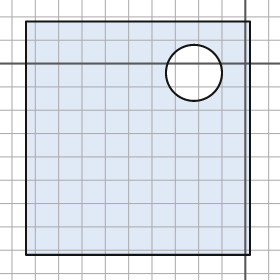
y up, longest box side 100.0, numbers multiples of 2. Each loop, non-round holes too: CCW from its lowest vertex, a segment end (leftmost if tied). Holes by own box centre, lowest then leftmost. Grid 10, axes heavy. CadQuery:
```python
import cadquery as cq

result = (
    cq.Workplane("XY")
    .moveTo(-94.0, -82.0)
    .lineTo(2.0, -82.0)
    .lineTo(2.0, 18.0)
    .lineTo(-94.0, 18.0)
    .close()
    .moveTo(-22.0, -4.0)
    .circle(12.0)
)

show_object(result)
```